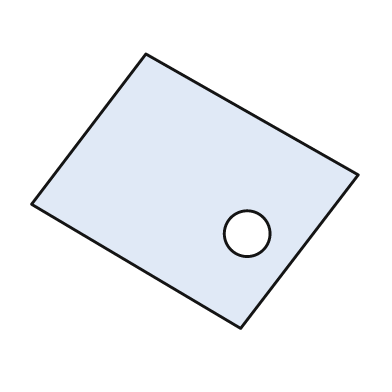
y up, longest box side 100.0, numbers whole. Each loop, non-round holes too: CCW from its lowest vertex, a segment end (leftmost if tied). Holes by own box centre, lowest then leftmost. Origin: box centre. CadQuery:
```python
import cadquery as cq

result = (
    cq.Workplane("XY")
    .moveTo(14.0, -42.0)
    .lineTo(50.0, 5.0)
    .lineTo(-15.0, 42.0)
    .lineTo(-50.0, -4.0)
    .close()
    .moveTo(16.0, -13.0)
    .circle(7.0)
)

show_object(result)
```